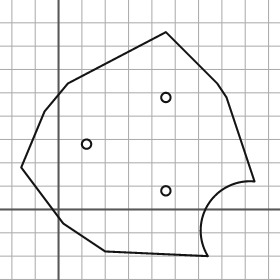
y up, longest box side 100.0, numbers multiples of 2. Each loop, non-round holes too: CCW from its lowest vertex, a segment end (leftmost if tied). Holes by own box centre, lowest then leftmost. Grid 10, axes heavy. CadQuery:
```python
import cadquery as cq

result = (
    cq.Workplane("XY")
    .moveTo(64.0, -20.0)
    .threePointArc((64.0, 2.0), (84.0, 12.0))
    .lineTo(72.0, 48.0)
    .lineTo(68.0, 54.0)
    .lineTo(46.0, 76.0)
    .lineTo(4.0, 54.0)
    .lineTo(-6.0, 42.0)
    .lineTo(-16.0, 18.0)
    .lineTo(2.0, -6.0)
    .lineTo(20.0, -18.0)
    .close()
    .moveTo(46.0, 8.0)
    .circle(2.0)
    .moveTo(12.0, 28.0)
    .circle(2.0)
    .moveTo(46.0, 48.0)
    .circle(2.0)
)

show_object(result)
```